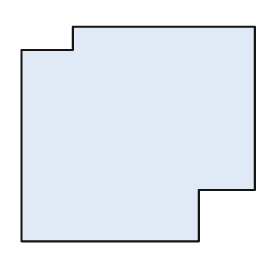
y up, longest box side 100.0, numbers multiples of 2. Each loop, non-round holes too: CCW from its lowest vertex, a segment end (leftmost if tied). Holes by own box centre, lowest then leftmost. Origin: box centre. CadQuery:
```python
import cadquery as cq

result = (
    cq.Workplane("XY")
    .moveTo(-50.0, -46.0)
    .lineTo(26.0, -46.0)
    .lineTo(26.0, -24.0)
    .lineTo(50.0, -24.0)
    .lineTo(50.0, 46.0)
    .lineTo(-28.0, 46.0)
    .lineTo(-28.0, 36.0)
    .lineTo(-50.0, 36.0)
    .close()
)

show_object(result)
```